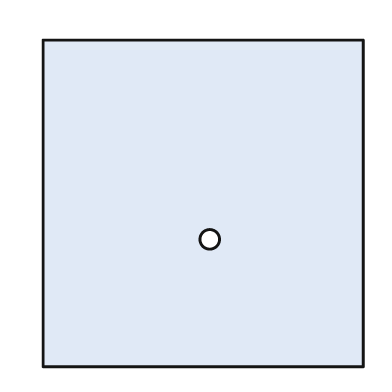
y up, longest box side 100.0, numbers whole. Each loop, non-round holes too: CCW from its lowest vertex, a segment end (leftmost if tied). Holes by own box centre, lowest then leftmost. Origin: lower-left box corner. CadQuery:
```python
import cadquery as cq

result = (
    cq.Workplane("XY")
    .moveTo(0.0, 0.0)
    .lineTo(98.0, 0.0)
    .lineTo(98.0, 100.0)
    .lineTo(0.0, 100.0)
    .close()
    .moveTo(51.0, 39.0)
    .circle(3.0)
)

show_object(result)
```